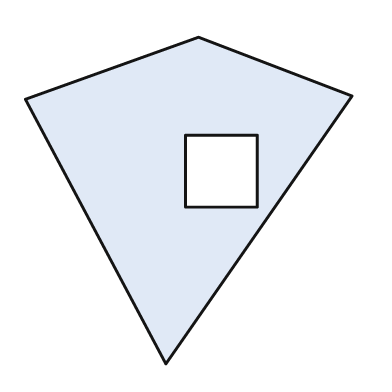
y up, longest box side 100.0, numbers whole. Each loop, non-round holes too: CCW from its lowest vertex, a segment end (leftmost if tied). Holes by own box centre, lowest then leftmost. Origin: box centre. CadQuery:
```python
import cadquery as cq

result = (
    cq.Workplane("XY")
    .moveTo(-7.0, -50.0)
    .lineTo(50.0, 32.0)
    .lineTo(3.0, 50.0)
    .lineTo(-50.0, 31.0)
    .close()
    .moveTo(-1.0, -2.0)
    .lineTo(21.0, -2.0)
    .lineTo(21.0, 20.0)
    .lineTo(-1.0, 20.0)
    .close()
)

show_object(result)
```